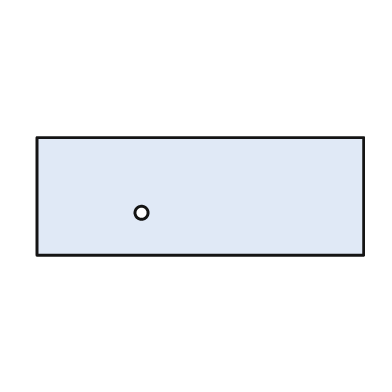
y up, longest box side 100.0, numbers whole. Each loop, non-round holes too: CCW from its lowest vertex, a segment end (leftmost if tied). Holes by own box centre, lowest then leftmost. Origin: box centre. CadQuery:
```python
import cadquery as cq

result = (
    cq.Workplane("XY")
    .moveTo(-50.0, -18.0)
    .lineTo(50.0, -18.0)
    .lineTo(50.0, 18.0)
    .lineTo(-50.0, 18.0)
    .close()
    .moveTo(-18.0, -5.0)
    .circle(2.0)
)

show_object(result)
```